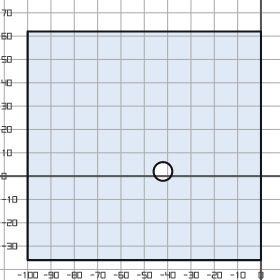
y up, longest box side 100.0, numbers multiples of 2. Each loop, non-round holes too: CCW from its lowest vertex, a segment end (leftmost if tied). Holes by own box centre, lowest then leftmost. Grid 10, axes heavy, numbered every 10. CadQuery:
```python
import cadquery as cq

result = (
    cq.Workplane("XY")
    .moveTo(-100.0, -36.0)
    .lineTo(0.0, -36.0)
    .lineTo(0.0, 62.0)
    .lineTo(-100.0, 62.0)
    .close()
    .moveTo(-42.0, 2.0)
    .circle(4.0)
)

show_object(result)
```